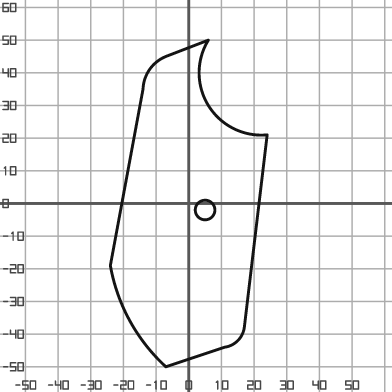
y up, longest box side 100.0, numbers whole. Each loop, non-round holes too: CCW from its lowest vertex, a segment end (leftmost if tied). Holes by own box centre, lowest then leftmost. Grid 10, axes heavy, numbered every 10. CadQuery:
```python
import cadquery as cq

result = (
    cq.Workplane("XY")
    .moveTo(-7.0, -50.0)
    .lineTo(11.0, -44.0)
    .threePointArc((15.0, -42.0), (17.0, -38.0))
    .lineTo(24.0, 21.0)
    .threePointArc((6.0, 30.0), (6.0, 50.0))
    .lineTo(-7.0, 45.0)
    .threePointArc((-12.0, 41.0), (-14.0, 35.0))
    .lineTo(-24.0, -19.0)
    .threePointArc((-18.0, -36.0), (-7.0, -50.0))
    .close()
    .moveTo(5.0, -2.0)
    .circle(3.0)
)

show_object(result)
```